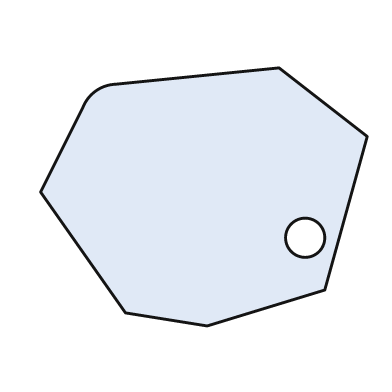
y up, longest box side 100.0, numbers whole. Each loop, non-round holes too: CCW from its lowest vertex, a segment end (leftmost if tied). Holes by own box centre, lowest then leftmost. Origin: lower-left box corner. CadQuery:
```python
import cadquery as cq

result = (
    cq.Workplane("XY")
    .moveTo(51.0, 0.0)
    .lineTo(87.0, 11.0)
    .lineTo(100.0, 58.0)
    .lineTo(73.0, 79.0)
    .lineTo(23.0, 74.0)
    .threePointArc((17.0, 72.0), (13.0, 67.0))
    .lineTo(0.0, 41.0)
    .lineTo(26.0, 4.0)
    .close()
    .moveTo(81.0, 27.0)
    .circle(6.0)
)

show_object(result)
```